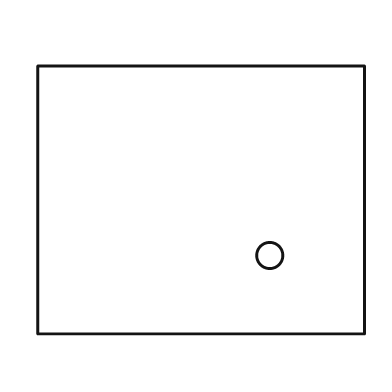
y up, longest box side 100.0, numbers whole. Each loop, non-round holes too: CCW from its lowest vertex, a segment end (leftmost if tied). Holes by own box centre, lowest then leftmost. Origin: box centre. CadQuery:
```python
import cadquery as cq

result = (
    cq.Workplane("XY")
    .moveTo(-50.0, -41.0)
    .lineTo(50.0, -41.0)
    .lineTo(50.0, 41.0)
    .lineTo(-50.0, 41.0)
    .close()
    .moveTo(21.0, -17.0)
    .circle(4.0)
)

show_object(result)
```